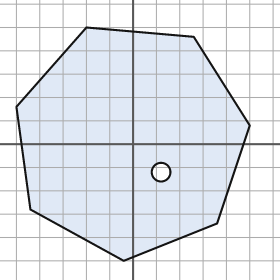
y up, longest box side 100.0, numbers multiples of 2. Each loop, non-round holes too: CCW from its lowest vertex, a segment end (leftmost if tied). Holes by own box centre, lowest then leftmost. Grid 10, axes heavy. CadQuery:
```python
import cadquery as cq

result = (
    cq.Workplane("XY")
    .moveTo(-4.0, -50.0)
    .lineTo(36.0, -34.0)
    .lineTo(50.0, 8.0)
    .lineTo(26.0, 46.0)
    .lineTo(-20.0, 50.0)
    .lineTo(-50.0, 16.0)
    .lineTo(-44.0, -28.0)
    .close()
    .moveTo(12.0, -12.0)
    .circle(4.0)
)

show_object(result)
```